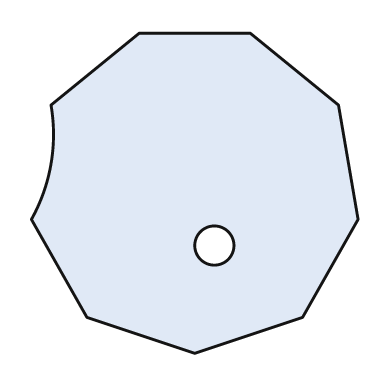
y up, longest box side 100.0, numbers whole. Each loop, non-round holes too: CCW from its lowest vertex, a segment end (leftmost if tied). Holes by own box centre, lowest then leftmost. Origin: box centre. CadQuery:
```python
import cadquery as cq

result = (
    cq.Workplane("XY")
    .moveTo(0.0, -49.0)
    .lineTo(33.0, -38.0)
    .lineTo(50.0, -8.0)
    .lineTo(44.0, 27.0)
    .lineTo(17.0, 49.0)
    .lineTo(-17.0, 49.0)
    .lineTo(-44.0, 27.0)
    .threePointArc((-44.0, 9.0), (-50.0, -8.0))
    .lineTo(-33.0, -38.0)
    .close()
    .moveTo(6.0, -16.0)
    .circle(6.0)
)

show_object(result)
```